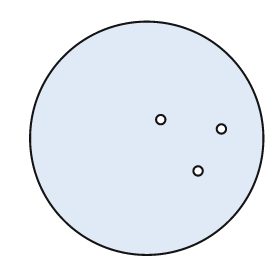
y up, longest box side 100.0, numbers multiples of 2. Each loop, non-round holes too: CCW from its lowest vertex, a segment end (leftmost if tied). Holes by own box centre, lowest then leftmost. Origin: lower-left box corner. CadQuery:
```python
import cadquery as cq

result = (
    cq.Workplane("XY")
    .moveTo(50.0, 50.0)
    .circle(50.0)
    .moveTo(72.0, 36.0)
    .circle(2.0)
    .moveTo(82.0, 54.0)
    .circle(2.0)
    .moveTo(56.0, 58.0)
    .circle(2.0)
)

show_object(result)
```